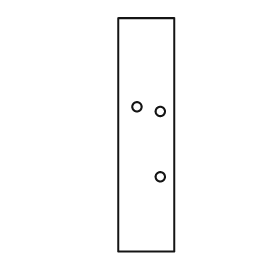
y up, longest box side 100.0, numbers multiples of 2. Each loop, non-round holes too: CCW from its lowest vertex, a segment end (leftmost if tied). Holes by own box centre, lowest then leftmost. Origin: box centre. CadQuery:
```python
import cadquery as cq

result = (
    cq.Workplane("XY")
    .moveTo(-12.0, -50.0)
    .lineTo(12.0, -50.0)
    .lineTo(12.0, 50.0)
    .lineTo(-12.0, 50.0)
    .close()
    .moveTo(6.0, -18.0)
    .circle(2.0)
    .moveTo(6.0, 10.0)
    .circle(2.0)
    .moveTo(-4.0, 12.0)
    .circle(2.0)
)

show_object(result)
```